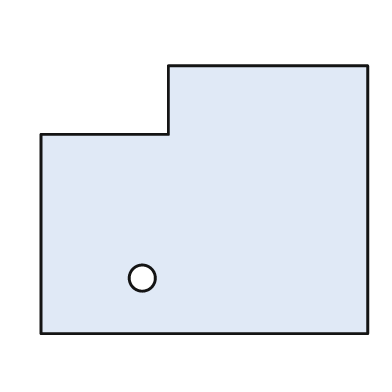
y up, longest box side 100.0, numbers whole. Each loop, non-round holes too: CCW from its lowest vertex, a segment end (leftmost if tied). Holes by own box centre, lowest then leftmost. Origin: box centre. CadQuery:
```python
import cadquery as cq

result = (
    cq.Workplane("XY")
    .moveTo(-50.0, -41.0)
    .lineTo(50.0, -41.0)
    .lineTo(50.0, 41.0)
    .lineTo(-11.0, 41.0)
    .lineTo(-11.0, 20.0)
    .lineTo(-50.0, 20.0)
    .close()
    .moveTo(-19.0, -24.0)
    .circle(4.0)
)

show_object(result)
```